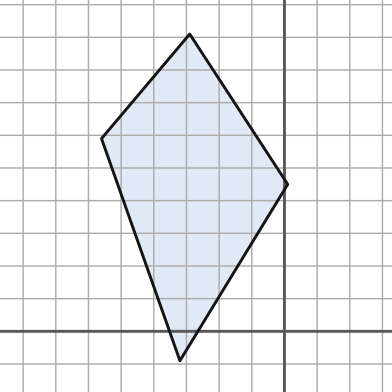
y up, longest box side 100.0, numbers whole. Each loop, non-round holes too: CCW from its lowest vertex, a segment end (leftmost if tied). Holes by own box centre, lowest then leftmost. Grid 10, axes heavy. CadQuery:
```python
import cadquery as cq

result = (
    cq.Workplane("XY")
    .moveTo(-32.0, -9.0)
    .lineTo(1.0, 45.0)
    .lineTo(-29.0, 91.0)
    .lineTo(-56.0, 59.0)
    .close()
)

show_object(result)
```